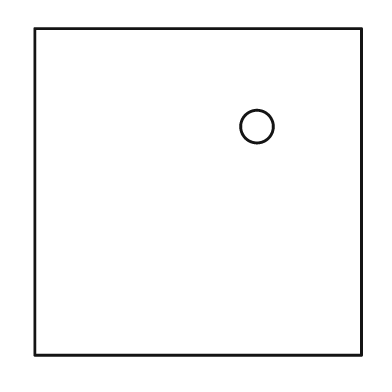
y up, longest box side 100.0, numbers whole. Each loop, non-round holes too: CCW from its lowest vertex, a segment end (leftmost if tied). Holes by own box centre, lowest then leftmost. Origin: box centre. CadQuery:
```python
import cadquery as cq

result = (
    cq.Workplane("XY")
    .moveTo(-50.0, -50.0)
    .lineTo(50.0, -50.0)
    .lineTo(50.0, 50.0)
    .lineTo(-50.0, 50.0)
    .close()
    .moveTo(18.0, 20.0)
    .circle(5.0)
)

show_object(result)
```